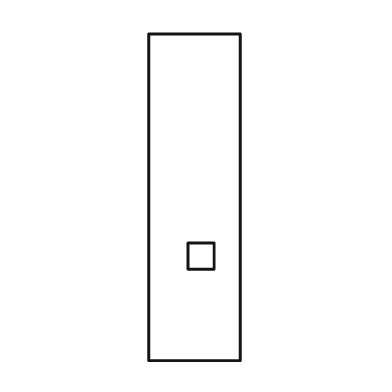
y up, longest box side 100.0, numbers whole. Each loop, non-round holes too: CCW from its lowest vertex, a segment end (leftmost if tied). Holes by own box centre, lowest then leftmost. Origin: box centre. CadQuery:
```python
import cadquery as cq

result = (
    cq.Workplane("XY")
    .moveTo(-14.0, -50.0)
    .lineTo(14.0, -50.0)
    .lineTo(14.0, 50.0)
    .lineTo(-14.0, 50.0)
    .close()
    .moveTo(-2.0, -22.0)
    .lineTo(6.0, -22.0)
    .lineTo(6.0, -14.0)
    .lineTo(-2.0, -14.0)
    .close()
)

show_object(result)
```